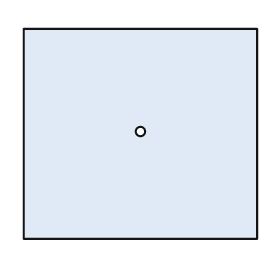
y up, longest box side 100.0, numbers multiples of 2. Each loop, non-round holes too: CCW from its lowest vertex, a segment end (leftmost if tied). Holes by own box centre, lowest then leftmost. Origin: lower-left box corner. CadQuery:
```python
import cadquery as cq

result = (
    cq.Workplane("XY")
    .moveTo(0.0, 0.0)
    .lineTo(100.0, 0.0)
    .lineTo(100.0, 90.0)
    .lineTo(0.0, 90.0)
    .close()
    .moveTo(50.0, 46.0)
    .circle(2.0)
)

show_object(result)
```